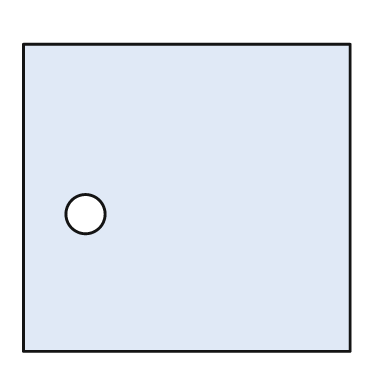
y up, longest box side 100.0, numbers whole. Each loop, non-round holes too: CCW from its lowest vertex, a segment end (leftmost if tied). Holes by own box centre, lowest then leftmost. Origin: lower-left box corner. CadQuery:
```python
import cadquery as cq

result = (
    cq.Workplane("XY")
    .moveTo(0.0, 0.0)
    .lineTo(100.0, 0.0)
    .lineTo(100.0, 94.0)
    .lineTo(0.0, 94.0)
    .close()
    .moveTo(19.0, 42.0)
    .circle(6.0)
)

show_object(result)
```